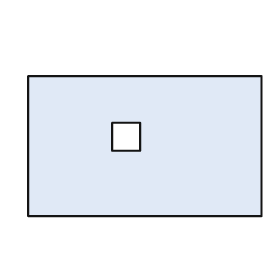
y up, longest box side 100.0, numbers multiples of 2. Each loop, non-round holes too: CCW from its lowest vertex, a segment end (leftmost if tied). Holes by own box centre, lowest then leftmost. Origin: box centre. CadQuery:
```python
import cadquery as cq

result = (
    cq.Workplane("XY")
    .moveTo(-50.0, -30.0)
    .lineTo(50.0, -30.0)
    .lineTo(50.0, 30.0)
    .lineTo(-50.0, 30.0)
    .close()
    .moveTo(-14.0, -2.0)
    .lineTo(-2.0, -2.0)
    .lineTo(-2.0, 10.0)
    .lineTo(-14.0, 10.0)
    .close()
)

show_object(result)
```